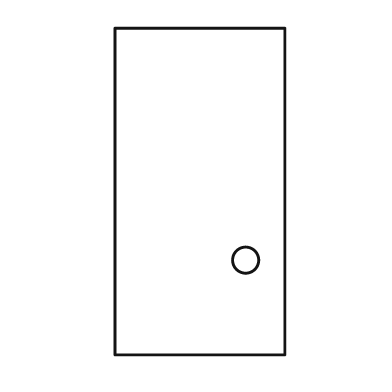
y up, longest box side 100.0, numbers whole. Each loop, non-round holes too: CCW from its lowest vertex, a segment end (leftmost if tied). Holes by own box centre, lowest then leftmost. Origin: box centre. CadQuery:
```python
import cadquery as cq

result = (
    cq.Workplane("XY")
    .moveTo(-26.0, -50.0)
    .lineTo(26.0, -50.0)
    .lineTo(26.0, 50.0)
    .lineTo(-26.0, 50.0)
    .close()
    .moveTo(14.0, -21.0)
    .circle(4.0)
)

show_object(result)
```